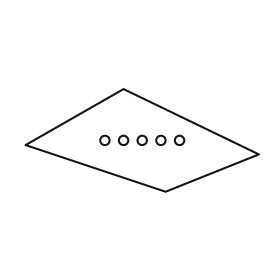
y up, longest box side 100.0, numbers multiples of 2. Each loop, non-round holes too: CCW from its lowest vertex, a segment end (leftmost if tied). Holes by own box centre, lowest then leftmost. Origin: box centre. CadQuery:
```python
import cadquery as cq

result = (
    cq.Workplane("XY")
    .moveTo(10.0, -22.0)
    .lineTo(50.0, -6.0)
    .lineTo(-8.0, 22.0)
    .lineTo(-50.0, -2.0)
    .close()
    .moveTo(-16.0, 0.0)
    .circle(2.0)
    .moveTo(-8.0, 0.0)
    .circle(2.0)
    .moveTo(0.0, 0.0)
    .circle(2.0)
    .moveTo(8.0, 0.0)
    .circle(2.0)
    .moveTo(16.0, 0.0)
    .circle(2.0)
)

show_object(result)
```